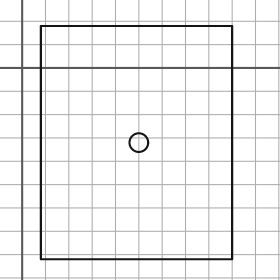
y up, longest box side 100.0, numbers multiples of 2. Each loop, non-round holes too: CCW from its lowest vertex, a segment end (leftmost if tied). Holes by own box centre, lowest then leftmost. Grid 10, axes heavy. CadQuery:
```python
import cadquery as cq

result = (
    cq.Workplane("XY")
    .moveTo(8.0, -82.0)
    .lineTo(90.0, -82.0)
    .lineTo(90.0, 18.0)
    .lineTo(8.0, 18.0)
    .close()
    .moveTo(50.0, -32.0)
    .circle(4.0)
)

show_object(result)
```